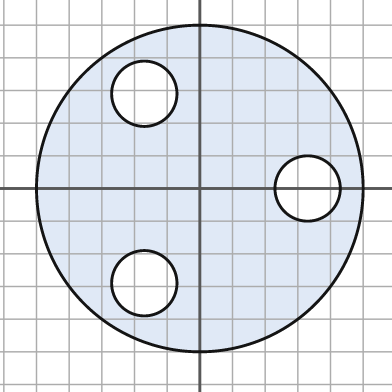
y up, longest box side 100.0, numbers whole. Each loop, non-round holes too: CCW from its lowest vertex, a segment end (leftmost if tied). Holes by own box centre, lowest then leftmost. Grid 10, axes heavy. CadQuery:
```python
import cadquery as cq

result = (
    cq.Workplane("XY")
    .moveTo(0.0, 0.0)
    .circle(50.0)
    .moveTo(-17.0, -29.0)
    .circle(10.0)
    .moveTo(33.0, 0.0)
    .circle(10.0)
    .moveTo(-17.0, 29.0)
    .circle(10.0)
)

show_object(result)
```